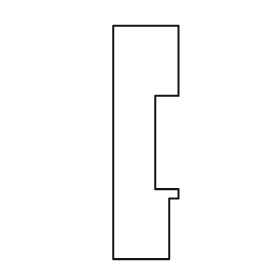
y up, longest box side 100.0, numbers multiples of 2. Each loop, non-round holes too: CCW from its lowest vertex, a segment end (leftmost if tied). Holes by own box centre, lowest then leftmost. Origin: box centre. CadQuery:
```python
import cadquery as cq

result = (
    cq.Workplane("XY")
    .moveTo(-14.0, -50.0)
    .lineTo(10.0, -50.0)
    .lineTo(10.0, -24.0)
    .lineTo(14.0, -24.0)
    .lineTo(14.0, -20.0)
    .lineTo(4.0, -20.0)
    .lineTo(4.0, 20.0)
    .lineTo(14.0, 20.0)
    .lineTo(14.0, 50.0)
    .lineTo(-14.0, 50.0)
    .close()
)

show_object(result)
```